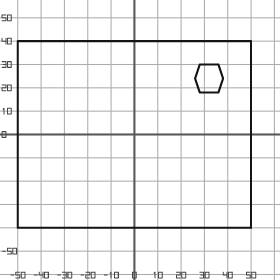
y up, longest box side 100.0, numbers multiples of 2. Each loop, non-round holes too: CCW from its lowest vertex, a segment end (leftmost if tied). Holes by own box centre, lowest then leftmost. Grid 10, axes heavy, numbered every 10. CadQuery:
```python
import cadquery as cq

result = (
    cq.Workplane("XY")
    .moveTo(-50.0, -40.0)
    .lineTo(50.0, -40.0)
    .lineTo(50.0, 40.0)
    .lineTo(-50.0, 40.0)
    .close()
    .moveTo(28.0, 18.0)
    .lineTo(36.0, 18.0)
    .lineTo(38.0, 24.0)
    .lineTo(36.0, 30.0)
    .lineTo(28.0, 30.0)
    .lineTo(26.0, 24.0)
    .close()
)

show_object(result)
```